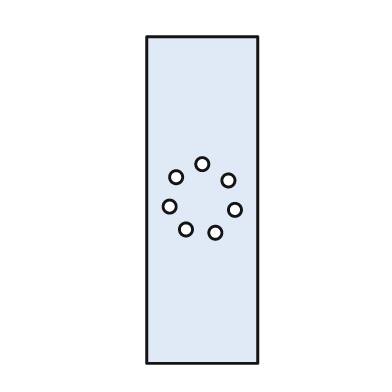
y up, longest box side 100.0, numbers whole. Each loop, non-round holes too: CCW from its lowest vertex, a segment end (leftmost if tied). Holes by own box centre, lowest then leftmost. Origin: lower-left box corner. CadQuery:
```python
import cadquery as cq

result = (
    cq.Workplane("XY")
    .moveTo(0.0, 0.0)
    .lineTo(34.0, 0.0)
    .lineTo(34.0, 100.0)
    .lineTo(0.0, 100.0)
    .close()
    .moveTo(21.0, 40.0)
    .circle(2.0)
    .moveTo(12.0, 41.0)
    .circle(2.0)
    .moveTo(27.0, 47.0)
    .circle(2.0)
    .moveTo(7.0, 48.0)
    .circle(2.0)
    .moveTo(25.0, 56.0)
    .circle(2.0)
    .moveTo(9.0, 57.0)
    .circle(2.0)
    .moveTo(17.0, 61.0)
    .circle(2.0)
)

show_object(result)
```